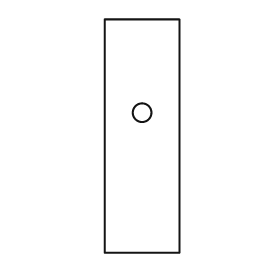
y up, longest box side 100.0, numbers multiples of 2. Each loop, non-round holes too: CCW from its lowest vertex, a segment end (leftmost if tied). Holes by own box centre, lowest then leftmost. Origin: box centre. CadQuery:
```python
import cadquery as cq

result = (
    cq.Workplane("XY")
    .moveTo(-16.0, -50.0)
    .lineTo(16.0, -50.0)
    .lineTo(16.0, 50.0)
    .lineTo(-16.0, 50.0)
    .close()
    .moveTo(0.0, 10.0)
    .circle(4.0)
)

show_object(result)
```